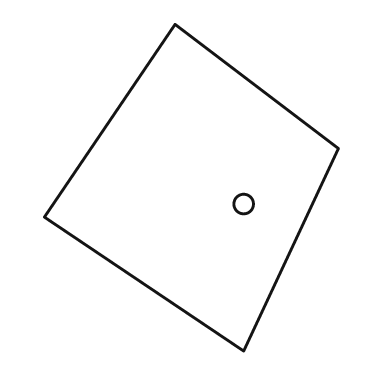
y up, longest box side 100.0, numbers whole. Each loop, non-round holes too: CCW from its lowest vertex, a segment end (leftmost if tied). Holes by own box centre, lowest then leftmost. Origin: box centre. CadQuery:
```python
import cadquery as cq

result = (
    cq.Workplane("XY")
    .moveTo(16.0, -50.0)
    .lineTo(45.0, 12.0)
    .lineTo(-5.0, 50.0)
    .lineTo(-45.0, -9.0)
    .close()
    .moveTo(16.0, -5.0)
    .circle(3.0)
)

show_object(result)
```